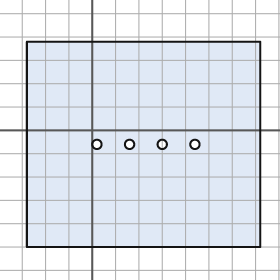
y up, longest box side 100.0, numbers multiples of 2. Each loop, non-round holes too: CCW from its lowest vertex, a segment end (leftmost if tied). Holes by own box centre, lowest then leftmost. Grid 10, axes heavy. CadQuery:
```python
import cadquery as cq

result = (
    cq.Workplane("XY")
    .moveTo(-28.0, -50.0)
    .lineTo(72.0, -50.0)
    .lineTo(72.0, 38.0)
    .lineTo(-28.0, 38.0)
    .close()
    .moveTo(2.0, -6.0)
    .circle(2.0)
    .moveTo(16.0, -6.0)
    .circle(2.0)
    .moveTo(30.0, -6.0)
    .circle(2.0)
    .moveTo(44.0, -6.0)
    .circle(2.0)
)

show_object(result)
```